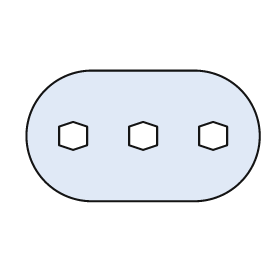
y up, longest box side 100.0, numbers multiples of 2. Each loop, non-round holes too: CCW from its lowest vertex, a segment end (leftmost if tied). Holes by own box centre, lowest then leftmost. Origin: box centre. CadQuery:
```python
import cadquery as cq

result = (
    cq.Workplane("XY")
    .moveTo(-22.0, -28.0)
    .lineTo(22.0, -28.0)
    .threePointArc((50.0, 0.0), (22.0, 28.0))
    .lineTo(-22.0, 28.0)
    .threePointArc((-50.0, 0.0), (-22.0, -28.0))
    .close()
    .moveTo(-30.0, -6.0)
    .lineTo(-24.0, -4.0)
    .lineTo(-24.0, 4.0)
    .lineTo(-30.0, 6.0)
    .lineTo(-36.0, 4.0)
    .lineTo(-36.0, -4.0)
    .close()
    .moveTo(0.0, -6.0)
    .lineTo(6.0, -4.0)
    .lineTo(6.0, 4.0)
    .lineTo(0.0, 6.0)
    .lineTo(-6.0, 4.0)
    .lineTo(-6.0, -4.0)
    .close()
    .moveTo(30.0, -6.0)
    .lineTo(36.0, -4.0)
    .lineTo(36.0, 4.0)
    .lineTo(30.0, 6.0)
    .lineTo(24.0, 4.0)
    .lineTo(24.0, -4.0)
    .close()
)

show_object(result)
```